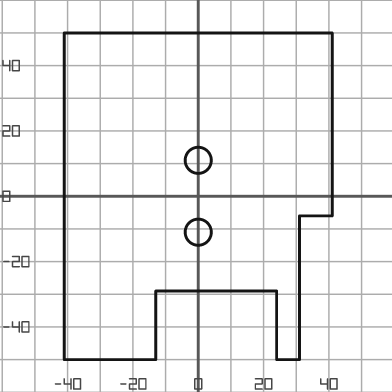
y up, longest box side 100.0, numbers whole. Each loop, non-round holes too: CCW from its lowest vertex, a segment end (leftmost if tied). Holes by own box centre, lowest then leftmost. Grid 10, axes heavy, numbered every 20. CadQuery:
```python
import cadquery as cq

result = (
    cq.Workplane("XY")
    .moveTo(-41.0, -50.0)
    .lineTo(-13.0, -50.0)
    .lineTo(-13.0, -29.0)
    .lineTo(24.0, -29.0)
    .lineTo(24.0, -50.0)
    .lineTo(31.0, -50.0)
    .lineTo(31.0, -6.0)
    .lineTo(41.0, -6.0)
    .lineTo(41.0, 50.0)
    .lineTo(-41.0, 50.0)
    .close()
    .moveTo(0.0, -11.0)
    .circle(4.0)
    .moveTo(0.0, 11.0)
    .circle(4.0)
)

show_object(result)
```